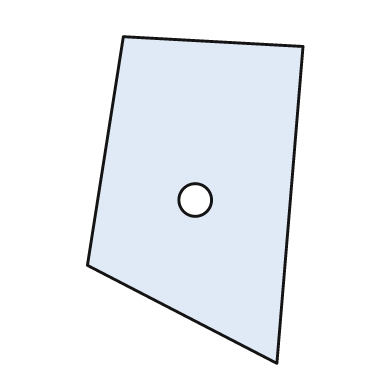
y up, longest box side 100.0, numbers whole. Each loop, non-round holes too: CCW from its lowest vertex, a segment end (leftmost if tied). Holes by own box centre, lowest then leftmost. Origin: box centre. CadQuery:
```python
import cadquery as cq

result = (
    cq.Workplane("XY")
    .moveTo(25.0, -50.0)
    .lineTo(33.0, 47.0)
    .lineTo(-22.0, 50.0)
    .lineTo(-33.0, -20.0)
    .close()
    .moveTo(0.0, 0.0)
    .circle(5.0)
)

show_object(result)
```